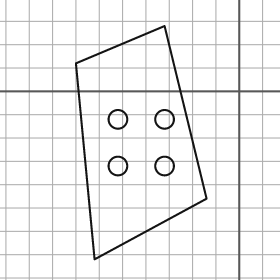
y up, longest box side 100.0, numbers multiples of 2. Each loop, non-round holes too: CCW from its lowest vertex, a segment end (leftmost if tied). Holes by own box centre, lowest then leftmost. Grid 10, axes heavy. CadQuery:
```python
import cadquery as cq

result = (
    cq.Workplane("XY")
    .moveTo(-62.0, -72.0)
    .lineTo(-14.0, -46.0)
    .lineTo(-32.0, 28.0)
    .lineTo(-70.0, 12.0)
    .close()
    .moveTo(-52.0, -32.0)
    .circle(4.0)
    .moveTo(-32.0, -32.0)
    .circle(4.0)
    .moveTo(-52.0, -12.0)
    .circle(4.0)
    .moveTo(-32.0, -12.0)
    .circle(4.0)
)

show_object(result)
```